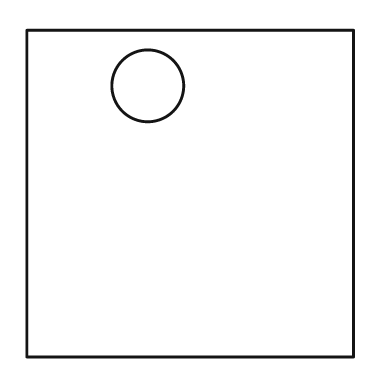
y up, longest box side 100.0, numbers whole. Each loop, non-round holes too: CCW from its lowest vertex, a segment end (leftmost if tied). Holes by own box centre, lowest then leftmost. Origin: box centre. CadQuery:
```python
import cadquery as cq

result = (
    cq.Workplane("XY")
    .moveTo(-50.0, -50.0)
    .lineTo(50.0, -50.0)
    .lineTo(50.0, 50.0)
    .lineTo(-50.0, 50.0)
    .close()
    .moveTo(-13.0, 33.0)
    .circle(11.0)
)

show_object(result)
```